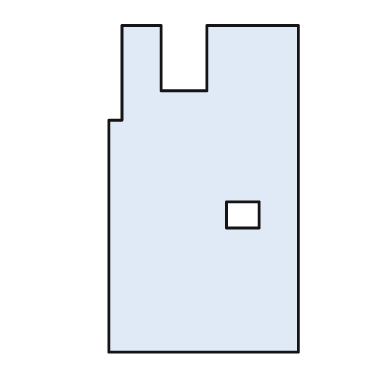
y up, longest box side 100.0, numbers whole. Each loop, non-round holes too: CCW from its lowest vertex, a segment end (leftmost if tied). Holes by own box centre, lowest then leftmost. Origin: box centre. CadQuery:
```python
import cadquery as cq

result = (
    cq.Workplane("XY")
    .moveTo(-29.0, -50.0)
    .lineTo(29.0, -50.0)
    .lineTo(29.0, 50.0)
    .lineTo(1.0, 50.0)
    .lineTo(1.0, 30.0)
    .lineTo(-13.0, 30.0)
    .lineTo(-13.0, 50.0)
    .lineTo(-25.0, 50.0)
    .lineTo(-25.0, 21.0)
    .lineTo(-29.0, 21.0)
    .close()
    .moveTo(7.0, -12.0)
    .lineTo(17.0, -12.0)
    .lineTo(17.0, -4.0)
    .lineTo(7.0, -4.0)
    .close()
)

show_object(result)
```